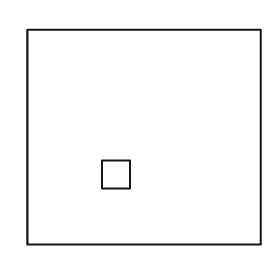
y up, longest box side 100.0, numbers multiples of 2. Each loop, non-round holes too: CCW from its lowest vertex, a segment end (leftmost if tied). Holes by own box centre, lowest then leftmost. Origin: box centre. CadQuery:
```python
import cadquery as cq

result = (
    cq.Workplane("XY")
    .moveTo(-50.0, -46.0)
    .lineTo(50.0, -46.0)
    .lineTo(50.0, 46.0)
    .lineTo(-50.0, 46.0)
    .close()
    .moveTo(-18.0, -22.0)
    .lineTo(-6.0, -22.0)
    .lineTo(-6.0, -10.0)
    .lineTo(-18.0, -10.0)
    .close()
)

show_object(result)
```